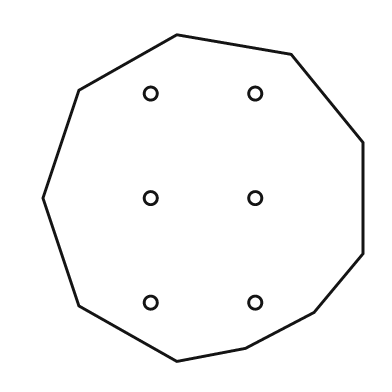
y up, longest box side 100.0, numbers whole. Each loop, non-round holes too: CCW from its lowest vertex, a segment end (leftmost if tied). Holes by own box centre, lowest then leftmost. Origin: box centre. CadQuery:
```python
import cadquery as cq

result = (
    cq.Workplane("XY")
    .moveTo(-8.0, -50.0)
    .lineTo(13.0, -46.0)
    .lineTo(34.0, -35.0)
    .lineTo(49.0, -17.0)
    .lineTo(49.0, 17.0)
    .lineTo(27.0, 44.0)
    .lineTo(-8.0, 50.0)
    .lineTo(-38.0, 33.0)
    .lineTo(-49.0, 0.0)
    .lineTo(-38.0, -33.0)
    .close()
    .moveTo(-16.0, -32.0)
    .circle(2.0)
    .moveTo(16.0, -32.0)
    .circle(2.0)
    .moveTo(-16.0, 0.0)
    .circle(2.0)
    .moveTo(16.0, 0.0)
    .circle(2.0)
    .moveTo(-16.0, 32.0)
    .circle(2.0)
    .moveTo(16.0, 32.0)
    .circle(2.0)
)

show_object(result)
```